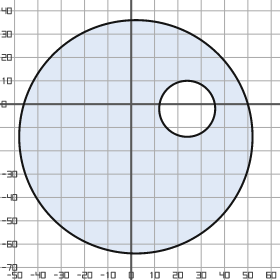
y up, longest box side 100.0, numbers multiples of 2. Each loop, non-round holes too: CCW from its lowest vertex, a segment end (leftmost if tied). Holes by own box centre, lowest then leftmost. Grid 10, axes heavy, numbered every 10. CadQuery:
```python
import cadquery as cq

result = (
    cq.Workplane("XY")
    .moveTo(2.0, -14.0)
    .circle(50.0)
    .moveTo(24.0, -2.0)
    .circle(12.0)
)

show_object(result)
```